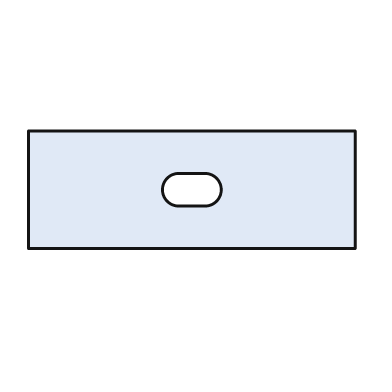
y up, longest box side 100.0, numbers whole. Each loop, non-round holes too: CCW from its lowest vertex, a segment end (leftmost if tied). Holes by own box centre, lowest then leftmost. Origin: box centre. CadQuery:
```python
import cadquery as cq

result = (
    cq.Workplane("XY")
    .moveTo(-50.0, -18.0)
    .lineTo(50.0, -18.0)
    .lineTo(50.0, 18.0)
    .lineTo(-50.0, 18.0)
    .close()
    .moveTo(-4.0, -5.0)
    .lineTo(4.0, -5.0)
    .threePointArc((9.0, 0.0), (4.0, 5.0))
    .lineTo(-4.0, 5.0)
    .threePointArc((-9.0, 0.0), (-4.0, -5.0))
    .close()
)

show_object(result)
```